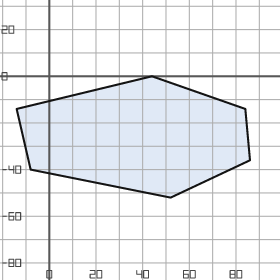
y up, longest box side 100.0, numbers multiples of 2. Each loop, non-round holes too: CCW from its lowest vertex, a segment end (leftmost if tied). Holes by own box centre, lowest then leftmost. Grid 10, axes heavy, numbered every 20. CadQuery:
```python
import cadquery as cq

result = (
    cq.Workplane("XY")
    .moveTo(52.0, -52.0)
    .lineTo(86.0, -36.0)
    .lineTo(84.0, -14.0)
    .lineTo(44.0, 0.0)
    .lineTo(-14.0, -14.0)
    .lineTo(-8.0, -40.0)
    .close()
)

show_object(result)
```